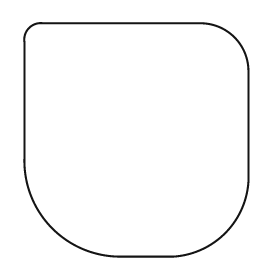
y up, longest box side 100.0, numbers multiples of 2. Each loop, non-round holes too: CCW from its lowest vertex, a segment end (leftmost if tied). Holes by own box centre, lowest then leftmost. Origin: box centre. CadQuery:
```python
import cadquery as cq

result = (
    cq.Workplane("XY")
    .moveTo(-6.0, -50.0)
    .lineTo(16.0, -50.0)
    .threePointArc((38.0, -40.0), (48.0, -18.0))
    .lineTo(48.0, 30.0)
    .threePointArc((42.0, 44.0), (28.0, 50.0))
    .lineTo(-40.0, 50.0)
    .threePointArc((-46.0, 48.0), (-48.0, 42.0))
    .lineTo(-48.0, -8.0)
    .threePointArc((-36.0, -38.0), (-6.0, -50.0))
    .close()
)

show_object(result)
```